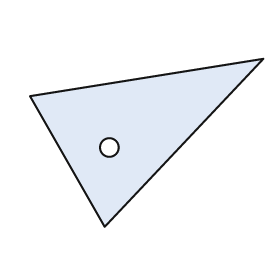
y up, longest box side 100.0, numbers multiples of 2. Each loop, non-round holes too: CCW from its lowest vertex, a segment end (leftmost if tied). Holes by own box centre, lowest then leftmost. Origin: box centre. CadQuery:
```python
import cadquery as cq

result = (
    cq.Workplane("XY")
    .moveTo(-18.0, -36.0)
    .lineTo(50.0, 36.0)
    .lineTo(-50.0, 20.0)
    .close()
    .moveTo(-16.0, -2.0)
    .circle(4.0)
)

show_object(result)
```